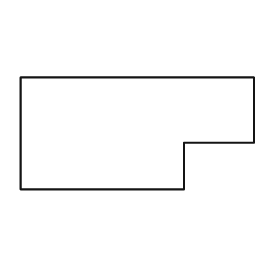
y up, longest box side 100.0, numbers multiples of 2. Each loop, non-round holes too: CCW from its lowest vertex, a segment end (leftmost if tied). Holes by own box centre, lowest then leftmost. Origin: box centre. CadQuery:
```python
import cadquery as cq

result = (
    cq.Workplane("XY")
    .moveTo(-50.0, -24.0)
    .lineTo(20.0, -24.0)
    .lineTo(20.0, -4.0)
    .lineTo(50.0, -4.0)
    .lineTo(50.0, 24.0)
    .lineTo(-50.0, 24.0)
    .close()
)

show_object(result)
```